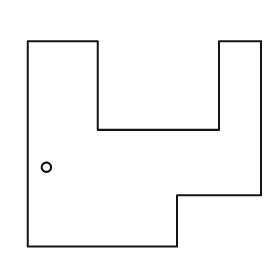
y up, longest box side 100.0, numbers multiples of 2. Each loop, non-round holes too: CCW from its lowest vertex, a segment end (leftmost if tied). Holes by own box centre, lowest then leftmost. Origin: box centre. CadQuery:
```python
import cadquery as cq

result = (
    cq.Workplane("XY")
    .moveTo(-50.0, -44.0)
    .lineTo(14.0, -44.0)
    .lineTo(14.0, -22.0)
    .lineTo(50.0, -22.0)
    .lineTo(50.0, 44.0)
    .lineTo(32.0, 44.0)
    .lineTo(32.0, 6.0)
    .lineTo(-20.0, 6.0)
    .lineTo(-20.0, 44.0)
    .lineTo(-50.0, 44.0)
    .close()
    .moveTo(-42.0, -10.0)
    .circle(2.0)
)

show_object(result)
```